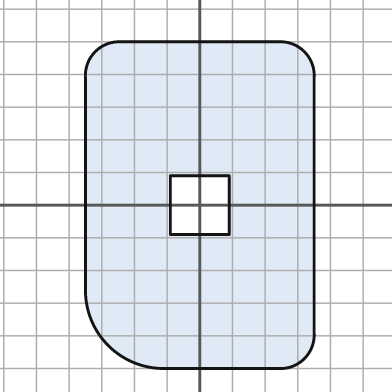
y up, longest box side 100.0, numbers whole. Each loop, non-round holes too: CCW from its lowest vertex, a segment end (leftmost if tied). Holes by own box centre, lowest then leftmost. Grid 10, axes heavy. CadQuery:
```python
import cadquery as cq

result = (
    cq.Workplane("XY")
    .moveTo(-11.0, -50.0)
    .lineTo(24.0, -50.0)
    .threePointArc((32.0, -47.0), (35.0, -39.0))
    .lineTo(35.0, 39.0)
    .threePointArc((32.0, 47.0), (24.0, 50.0))
    .lineTo(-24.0, 50.0)
    .threePointArc((-32.0, 47.0), (-35.0, 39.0))
    .lineTo(-35.0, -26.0)
    .threePointArc((-28.0, -43.0), (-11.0, -50.0))
    .close()
    .moveTo(-9.0, -9.0)
    .lineTo(9.0, -9.0)
    .lineTo(9.0, 9.0)
    .lineTo(-9.0, 9.0)
    .close()
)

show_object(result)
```